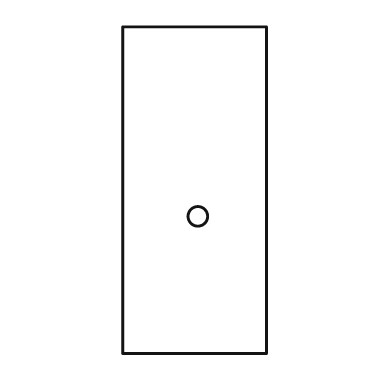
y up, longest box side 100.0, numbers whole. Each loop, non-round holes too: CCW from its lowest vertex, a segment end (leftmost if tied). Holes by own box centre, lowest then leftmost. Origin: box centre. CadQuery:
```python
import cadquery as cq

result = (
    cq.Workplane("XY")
    .moveTo(-22.0, -50.0)
    .lineTo(22.0, -50.0)
    .lineTo(22.0, 50.0)
    .lineTo(-22.0, 50.0)
    .close()
    .moveTo(1.0, -8.0)
    .circle(3.0)
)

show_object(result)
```